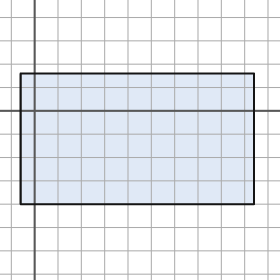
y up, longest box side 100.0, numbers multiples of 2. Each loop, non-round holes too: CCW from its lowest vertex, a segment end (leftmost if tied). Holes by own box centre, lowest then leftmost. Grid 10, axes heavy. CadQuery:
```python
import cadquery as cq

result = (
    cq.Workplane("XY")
    .moveTo(-6.0, -40.0)
    .lineTo(94.0, -40.0)
    .lineTo(94.0, 16.0)
    .lineTo(-6.0, 16.0)
    .close()
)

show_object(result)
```